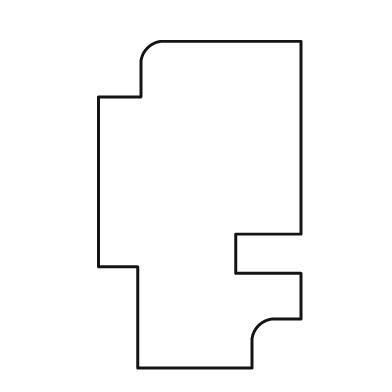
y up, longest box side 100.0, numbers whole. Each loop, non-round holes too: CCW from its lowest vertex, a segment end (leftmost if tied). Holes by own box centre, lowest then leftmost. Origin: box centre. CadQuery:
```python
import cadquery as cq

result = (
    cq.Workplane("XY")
    .moveTo(-19.0, -50.0)
    .lineTo(16.0, -50.0)
    .lineTo(16.0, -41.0)
    .threePointArc((18.0, -37.0), (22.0, -35.0))
    .lineTo(31.0, -35.0)
    .lineTo(31.0, -21.0)
    .lineTo(11.0, -21.0)
    .lineTo(11.0, -9.0)
    .lineTo(31.0, -9.0)
    .lineTo(31.0, 50.0)
    .lineTo(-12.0, 50.0)
    .threePointArc((-16.0, 48.0), (-18.0, 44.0))
    .lineTo(-18.0, 33.0)
    .lineTo(-31.0, 33.0)
    .lineTo(-31.0, -19.0)
    .lineTo(-19.0, -19.0)
    .close()
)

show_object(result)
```